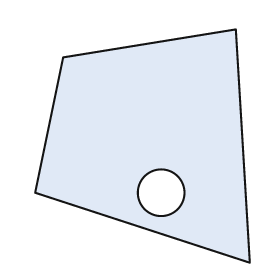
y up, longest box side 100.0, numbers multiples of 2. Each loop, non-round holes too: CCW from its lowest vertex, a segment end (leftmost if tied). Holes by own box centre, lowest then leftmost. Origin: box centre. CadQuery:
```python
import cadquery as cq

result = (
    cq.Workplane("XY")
    .moveTo(46.0, -50.0)
    .lineTo(40.0, 50.0)
    .lineTo(-34.0, 38.0)
    .lineTo(-46.0, -20.0)
    .close()
    .moveTo(8.0, -20.0)
    .circle(10.0)
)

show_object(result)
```